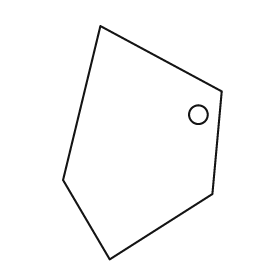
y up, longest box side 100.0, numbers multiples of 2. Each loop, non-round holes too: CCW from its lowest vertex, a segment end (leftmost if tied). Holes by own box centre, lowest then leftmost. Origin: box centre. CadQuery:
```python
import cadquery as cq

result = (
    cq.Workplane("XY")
    .moveTo(-14.0, -50.0)
    .lineTo(30.0, -22.0)
    .lineTo(34.0, 22.0)
    .lineTo(-18.0, 50.0)
    .lineTo(-34.0, -16.0)
    .close()
    .moveTo(24.0, 12.0)
    .circle(4.0)
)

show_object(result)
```